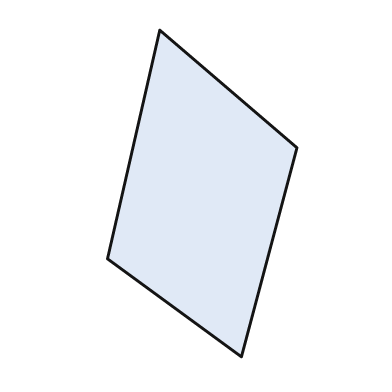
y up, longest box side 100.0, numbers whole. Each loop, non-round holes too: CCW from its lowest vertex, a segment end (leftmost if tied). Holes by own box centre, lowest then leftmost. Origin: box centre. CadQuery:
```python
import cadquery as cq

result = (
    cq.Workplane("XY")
    .moveTo(12.0, -50.0)
    .lineTo(29.0, 14.0)
    .lineTo(-13.0, 50.0)
    .lineTo(-29.0, -20.0)
    .close()
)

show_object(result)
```